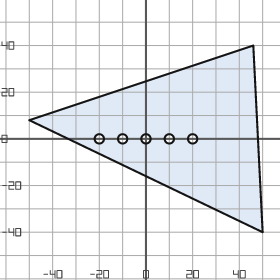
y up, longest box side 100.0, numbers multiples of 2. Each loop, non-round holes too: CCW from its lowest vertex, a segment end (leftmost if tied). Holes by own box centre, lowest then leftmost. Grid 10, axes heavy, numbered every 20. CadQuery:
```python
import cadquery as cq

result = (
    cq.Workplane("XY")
    .moveTo(50.0, -40.0)
    .lineTo(46.0, 40.0)
    .lineTo(-50.0, 8.0)
    .close()
    .moveTo(-20.0, 0.0)
    .circle(2.0)
    .moveTo(-10.0, 0.0)
    .circle(2.0)
    .moveTo(0.0, 0.0)
    .circle(2.0)
    .moveTo(10.0, 0.0)
    .circle(2.0)
    .moveTo(20.0, 0.0)
    .circle(2.0)
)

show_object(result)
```